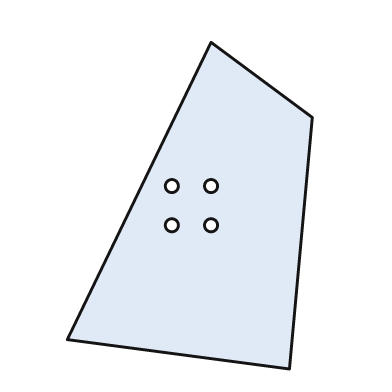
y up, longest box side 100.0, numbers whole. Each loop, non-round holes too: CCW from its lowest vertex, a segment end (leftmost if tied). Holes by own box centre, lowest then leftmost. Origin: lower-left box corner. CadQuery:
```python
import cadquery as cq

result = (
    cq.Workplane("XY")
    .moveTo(68.0, 0.0)
    .lineTo(75.0, 77.0)
    .lineTo(44.0, 100.0)
    .lineTo(0.0, 9.0)
    .close()
    .moveTo(32.0, 44.0)
    .circle(2.0)
    .moveTo(44.0, 44.0)
    .circle(2.0)
    .moveTo(32.0, 56.0)
    .circle(2.0)
    .moveTo(44.0, 56.0)
    .circle(2.0)
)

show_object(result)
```